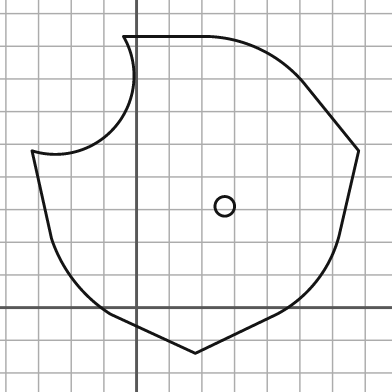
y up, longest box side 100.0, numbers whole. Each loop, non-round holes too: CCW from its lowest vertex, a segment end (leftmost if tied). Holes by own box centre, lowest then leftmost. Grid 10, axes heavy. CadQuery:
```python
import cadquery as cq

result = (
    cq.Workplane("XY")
    .moveTo(18.0, -14.0)
    .lineTo(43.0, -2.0)
    .threePointArc((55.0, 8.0), (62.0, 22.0))
    .lineTo(68.0, 48.0)
    .lineTo(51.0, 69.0)
    .threePointArc((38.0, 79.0), (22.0, 83.0))
    .lineTo(-4.0, 83.0)
    .threePointArc((-6.0, 56.0), (-32.0, 48.0))
    .lineTo(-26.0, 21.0)
    .threePointArc((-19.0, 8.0), (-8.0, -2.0))
    .close()
    .moveTo(27.0, 31.0)
    .circle(3.0)
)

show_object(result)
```